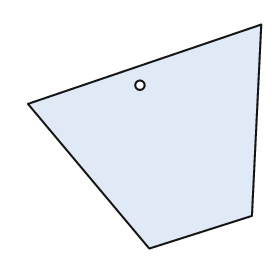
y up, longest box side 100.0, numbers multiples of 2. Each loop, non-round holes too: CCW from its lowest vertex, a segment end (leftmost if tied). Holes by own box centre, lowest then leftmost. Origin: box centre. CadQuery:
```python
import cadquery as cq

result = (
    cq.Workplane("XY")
    .moveTo(2.0, -48.0)
    .lineTo(46.0, -34.0)
    .lineTo(50.0, 48.0)
    .lineTo(-50.0, 14.0)
    .close()
    .moveTo(-2.0, 22.0)
    .circle(2.0)
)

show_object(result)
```